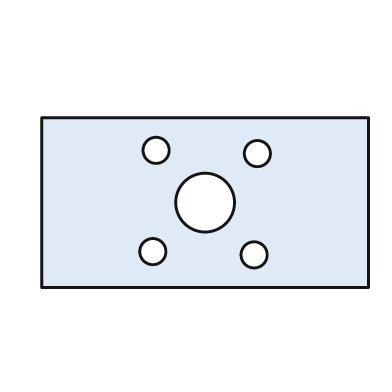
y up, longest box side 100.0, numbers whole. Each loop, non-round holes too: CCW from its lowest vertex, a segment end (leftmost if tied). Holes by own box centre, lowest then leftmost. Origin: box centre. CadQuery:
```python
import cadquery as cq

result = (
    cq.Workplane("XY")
    .moveTo(-50.0, -26.0)
    .lineTo(50.0, -26.0)
    .lineTo(50.0, 26.0)
    .lineTo(-50.0, 26.0)
    .close()
    .moveTo(15.0, -16.0)
    .circle(4.0)
    .moveTo(-16.0, -15.0)
    .circle(4.0)
    .moveTo(0.0, 0.0)
    .circle(9.0)
    .moveTo(16.0, 15.0)
    .circle(4.0)
    .moveTo(-15.0, 16.0)
    .circle(4.0)
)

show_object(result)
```